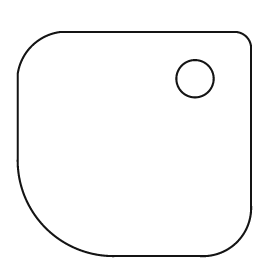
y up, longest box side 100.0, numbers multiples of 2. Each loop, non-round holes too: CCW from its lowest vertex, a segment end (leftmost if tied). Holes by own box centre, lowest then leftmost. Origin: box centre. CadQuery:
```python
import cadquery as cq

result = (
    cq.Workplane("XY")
    .moveTo(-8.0, -48.0)
    .lineTo(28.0, -48.0)
    .threePointArc((44.0, -42.0), (50.0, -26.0))
    .lineTo(50.0, 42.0)
    .threePointArc((48.0, 46.0), (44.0, 48.0))
    .lineTo(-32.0, 48.0)
    .threePointArc((-44.0, 42.0), (-50.0, 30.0))
    .lineTo(-50.0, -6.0)
    .threePointArc((-38.0, -36.0), (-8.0, -48.0))
    .close()
    .moveTo(26.0, 28.0)
    .circle(8.0)
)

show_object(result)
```